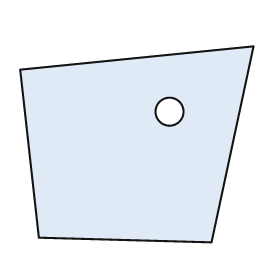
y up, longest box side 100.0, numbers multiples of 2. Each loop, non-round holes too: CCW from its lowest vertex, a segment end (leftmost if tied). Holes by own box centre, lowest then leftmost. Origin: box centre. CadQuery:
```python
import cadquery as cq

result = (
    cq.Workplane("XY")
    .moveTo(32.0, -42.0)
    .lineTo(50.0, 42.0)
    .lineTo(-50.0, 32.0)
    .lineTo(-42.0, -40.0)
    .close()
    .moveTo(14.0, 14.0)
    .circle(6.0)
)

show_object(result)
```